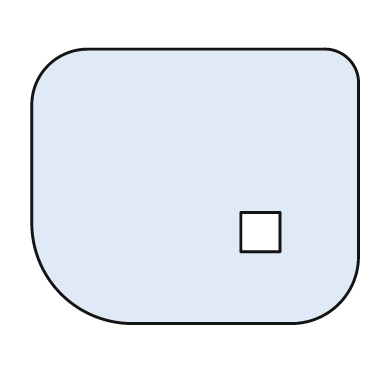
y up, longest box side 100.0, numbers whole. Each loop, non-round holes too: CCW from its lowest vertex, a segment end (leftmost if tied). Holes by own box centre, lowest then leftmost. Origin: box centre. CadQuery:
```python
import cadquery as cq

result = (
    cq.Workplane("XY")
    .moveTo(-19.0, -42.0)
    .lineTo(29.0, -42.0)
    .threePointArc((44.0, -36.0), (50.0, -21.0))
    .lineTo(50.0, 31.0)
    .threePointArc((47.0, 39.0), (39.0, 42.0))
    .lineTo(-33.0, 42.0)
    .threePointArc((-45.0, 37.0), (-50.0, 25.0))
    .lineTo(-50.0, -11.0)
    .threePointArc((-41.0, -33.0), (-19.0, -42.0))
    .close()
    .moveTo(14.0, -20.0)
    .lineTo(26.0, -20.0)
    .lineTo(26.0, -8.0)
    .lineTo(14.0, -8.0)
    .close()
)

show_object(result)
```